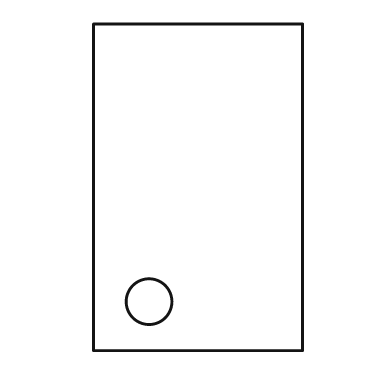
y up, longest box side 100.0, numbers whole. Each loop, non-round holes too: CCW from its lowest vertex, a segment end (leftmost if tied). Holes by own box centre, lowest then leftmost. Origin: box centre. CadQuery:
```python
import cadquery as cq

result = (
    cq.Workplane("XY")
    .moveTo(-32.0, -50.0)
    .lineTo(32.0, -50.0)
    .lineTo(32.0, 50.0)
    .lineTo(-32.0, 50.0)
    .close()
    .moveTo(-15.0, -35.0)
    .circle(7.0)
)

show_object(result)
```